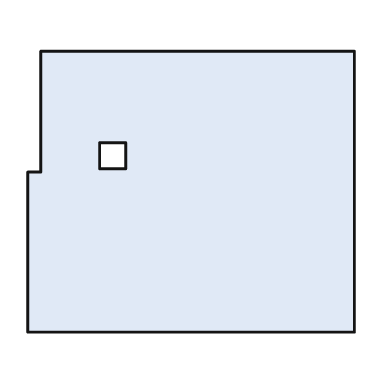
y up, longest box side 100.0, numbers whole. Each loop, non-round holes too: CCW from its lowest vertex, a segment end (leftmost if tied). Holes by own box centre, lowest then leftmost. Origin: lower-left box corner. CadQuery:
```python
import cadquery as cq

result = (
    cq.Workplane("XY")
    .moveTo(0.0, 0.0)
    .lineTo(100.0, 0.0)
    .lineTo(100.0, 86.0)
    .lineTo(4.0, 86.0)
    .lineTo(4.0, 49.0)
    .lineTo(0.0, 49.0)
    .close()
    .moveTo(22.0, 50.0)
    .lineTo(30.0, 50.0)
    .lineTo(30.0, 58.0)
    .lineTo(22.0, 58.0)
    .close()
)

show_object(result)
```